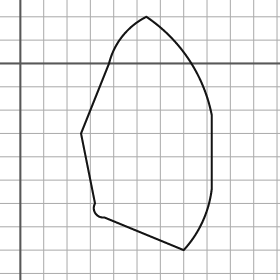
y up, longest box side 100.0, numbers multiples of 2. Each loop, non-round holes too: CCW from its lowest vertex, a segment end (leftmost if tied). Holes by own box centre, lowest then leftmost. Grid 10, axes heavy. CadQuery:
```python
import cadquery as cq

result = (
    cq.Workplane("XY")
    .moveTo(70.0, -80.0)
    .threePointArc((78.0, -68.0), (82.0, -54.0))
    .lineTo(82.0, -22.0)
    .threePointArc((72.0, 2.0), (54.0, 20.0))
    .threePointArc((44.0, 12.0), (38.0, 0.0))
    .lineTo(26.0, -30.0)
    .lineTo(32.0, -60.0)
    .threePointArc((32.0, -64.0), (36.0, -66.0))
    .close()
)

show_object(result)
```